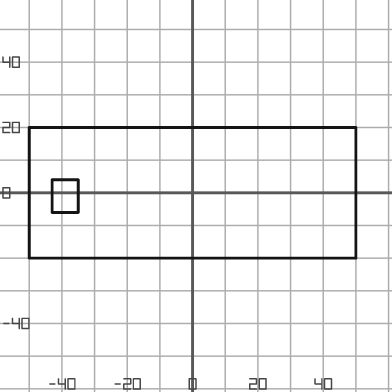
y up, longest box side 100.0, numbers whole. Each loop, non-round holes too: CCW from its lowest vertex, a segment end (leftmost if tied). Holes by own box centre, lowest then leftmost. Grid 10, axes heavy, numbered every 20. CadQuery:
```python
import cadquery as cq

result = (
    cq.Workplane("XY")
    .moveTo(-50.0, -20.0)
    .lineTo(50.0, -20.0)
    .lineTo(50.0, 20.0)
    .lineTo(-50.0, 20.0)
    .close()
    .moveTo(-43.0, -6.0)
    .lineTo(-35.0, -6.0)
    .lineTo(-35.0, 4.0)
    .lineTo(-43.0, 4.0)
    .close()
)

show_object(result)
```